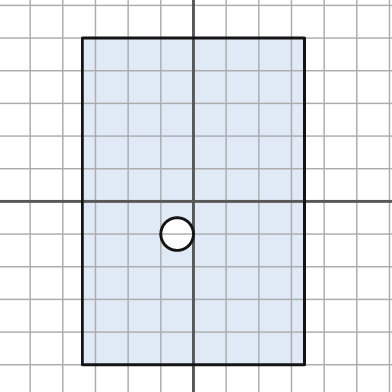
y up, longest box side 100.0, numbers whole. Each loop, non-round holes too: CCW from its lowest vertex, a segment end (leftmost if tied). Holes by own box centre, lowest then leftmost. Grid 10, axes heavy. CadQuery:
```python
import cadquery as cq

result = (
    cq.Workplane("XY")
    .moveTo(-34.0, -50.0)
    .lineTo(34.0, -50.0)
    .lineTo(34.0, 50.0)
    .lineTo(-34.0, 50.0)
    .close()
    .moveTo(-5.0, -10.0)
    .circle(5.0)
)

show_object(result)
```